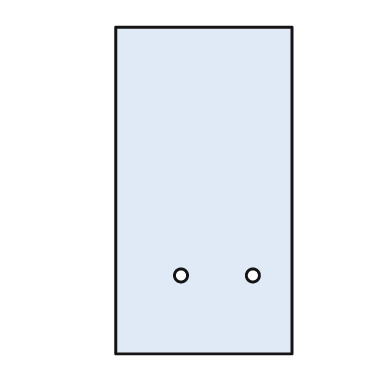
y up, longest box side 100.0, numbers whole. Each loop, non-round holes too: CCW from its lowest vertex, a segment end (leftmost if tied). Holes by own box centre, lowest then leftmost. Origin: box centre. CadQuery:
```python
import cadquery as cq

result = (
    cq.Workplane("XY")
    .moveTo(-27.0, -50.0)
    .lineTo(27.0, -50.0)
    .lineTo(27.0, 50.0)
    .lineTo(-27.0, 50.0)
    .close()
    .moveTo(-7.0, -26.0)
    .circle(2.0)
    .moveTo(15.0, -26.0)
    .circle(2.0)
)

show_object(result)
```